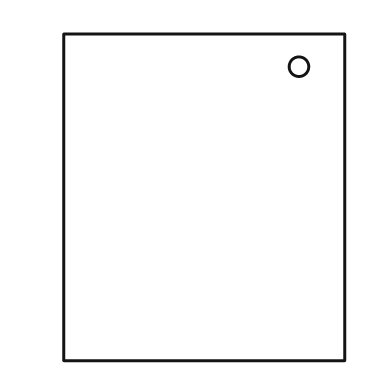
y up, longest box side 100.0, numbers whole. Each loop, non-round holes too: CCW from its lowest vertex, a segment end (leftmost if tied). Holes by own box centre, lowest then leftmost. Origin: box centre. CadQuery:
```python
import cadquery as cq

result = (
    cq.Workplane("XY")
    .moveTo(-43.0, -50.0)
    .lineTo(43.0, -50.0)
    .lineTo(43.0, 50.0)
    .lineTo(-43.0, 50.0)
    .close()
    .moveTo(29.0, 40.0)
    .circle(3.0)
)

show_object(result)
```